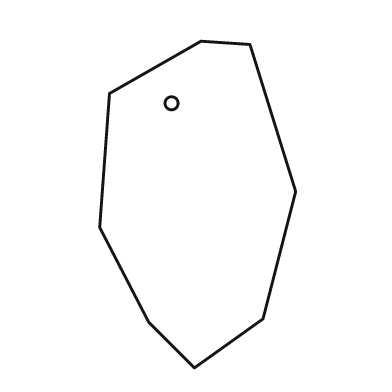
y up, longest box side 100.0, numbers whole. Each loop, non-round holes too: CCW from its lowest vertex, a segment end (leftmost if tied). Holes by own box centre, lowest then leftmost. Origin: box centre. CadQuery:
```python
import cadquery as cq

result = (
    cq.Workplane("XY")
    .moveTo(-1.0, -50.0)
    .lineTo(20.0, -35.0)
    .lineTo(30.0, 4.0)
    .lineTo(16.0, 49.0)
    .lineTo(1.0, 50.0)
    .lineTo(-27.0, 34.0)
    .lineTo(-30.0, -7.0)
    .lineTo(-15.0, -36.0)
    .close()
    .moveTo(-8.0, 31.0)
    .circle(2.0)
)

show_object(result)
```